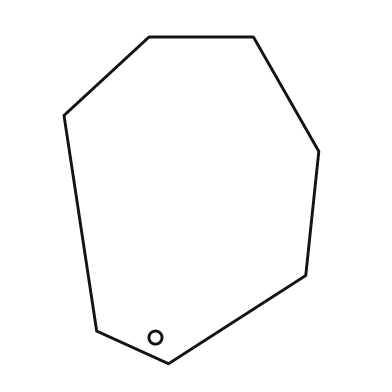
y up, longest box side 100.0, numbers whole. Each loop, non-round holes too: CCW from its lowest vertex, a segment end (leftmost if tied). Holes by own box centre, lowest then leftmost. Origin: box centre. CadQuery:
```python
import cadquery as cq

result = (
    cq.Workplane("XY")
    .moveTo(-7.0, -50.0)
    .lineTo(35.0, -23.0)
    .lineTo(39.0, 15.0)
    .lineTo(19.0, 50.0)
    .lineTo(-13.0, 50.0)
    .lineTo(-39.0, 26.0)
    .lineTo(-29.0, -40.0)
    .close()
    .moveTo(-11.0, -42.0)
    .circle(2.0)
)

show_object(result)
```